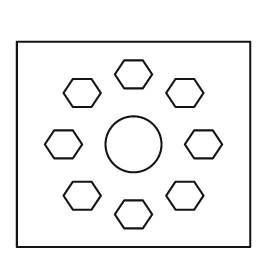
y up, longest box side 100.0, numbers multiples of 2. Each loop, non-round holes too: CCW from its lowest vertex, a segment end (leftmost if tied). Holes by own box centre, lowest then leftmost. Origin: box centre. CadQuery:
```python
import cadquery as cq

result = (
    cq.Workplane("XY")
    .moveTo(-50.0, -44.0)
    .lineTo(50.0, -44.0)
    .lineTo(50.0, 44.0)
    .lineTo(-50.0, 44.0)
    .close()
    .moveTo(-4.0, -36.0)
    .lineTo(4.0, -36.0)
    .lineTo(8.0, -30.0)
    .lineTo(4.0, -24.0)
    .lineTo(-4.0, -24.0)
    .lineTo(-8.0, -30.0)
    .close()
    .moveTo(-26.0, -28.0)
    .lineTo(-18.0, -28.0)
    .lineTo(-14.0, -22.0)
    .lineTo(-18.0, -16.0)
    .lineTo(-26.0, -16.0)
    .lineTo(-30.0, -22.0)
    .close()
    .moveTo(18.0, -28.0)
    .lineTo(26.0, -28.0)
    .lineTo(30.0, -22.0)
    .lineTo(26.0, -16.0)
    .lineTo(18.0, -16.0)
    .lineTo(14.0, -22.0)
    .close()
    .moveTo(-34.0, -6.0)
    .lineTo(-26.0, -6.0)
    .lineTo(-22.0, 0.0)
    .lineTo(-26.0, 6.0)
    .lineTo(-34.0, 6.0)
    .lineTo(-38.0, 0.0)
    .close()
    .moveTo(0.0, 0.0)
    .circle(12.0)
    .moveTo(26.0, -6.0)
    .lineTo(34.0, -6.0)
    .lineTo(38.0, 0.0)
    .lineTo(34.0, 6.0)
    .lineTo(26.0, 6.0)
    .lineTo(22.0, 0.0)
    .close()
    .moveTo(-26.0, 16.0)
    .lineTo(-18.0, 16.0)
    .lineTo(-14.0, 22.0)
    .lineTo(-18.0, 28.0)
    .lineTo(-26.0, 28.0)
    .lineTo(-30.0, 22.0)
    .close()
    .moveTo(18.0, 16.0)
    .lineTo(26.0, 16.0)
    .lineTo(30.0, 22.0)
    .lineTo(26.0, 28.0)
    .lineTo(18.0, 28.0)
    .lineTo(14.0, 22.0)
    .close()
    .moveTo(-4.0, 24.0)
    .lineTo(4.0, 24.0)
    .lineTo(8.0, 30.0)
    .lineTo(4.0, 36.0)
    .lineTo(-4.0, 36.0)
    .lineTo(-8.0, 30.0)
    .close()
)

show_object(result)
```